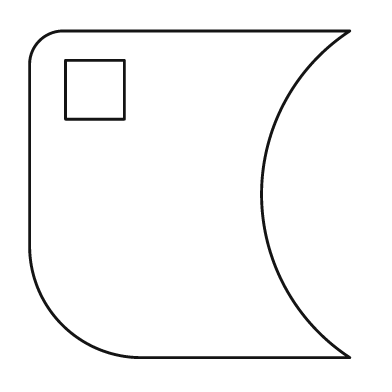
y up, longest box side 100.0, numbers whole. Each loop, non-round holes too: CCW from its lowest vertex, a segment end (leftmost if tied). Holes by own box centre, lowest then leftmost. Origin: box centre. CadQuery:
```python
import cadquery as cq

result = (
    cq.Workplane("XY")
    .moveTo(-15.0, -50.0)
    .lineTo(49.0, -50.0)
    .threePointArc((22.0, 0.0), (49.0, 50.0))
    .lineTo(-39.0, 50.0)
    .threePointArc((-46.0, 47.0), (-49.0, 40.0))
    .lineTo(-49.0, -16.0)
    .threePointArc((-39.0, -40.0), (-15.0, -50.0))
    .close()
    .moveTo(-38.0, 23.0)
    .lineTo(-20.0, 23.0)
    .lineTo(-20.0, 41.0)
    .lineTo(-38.0, 41.0)
    .close()
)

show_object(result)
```